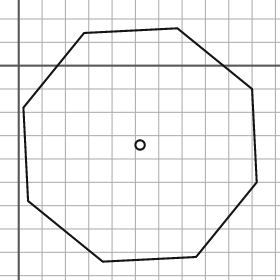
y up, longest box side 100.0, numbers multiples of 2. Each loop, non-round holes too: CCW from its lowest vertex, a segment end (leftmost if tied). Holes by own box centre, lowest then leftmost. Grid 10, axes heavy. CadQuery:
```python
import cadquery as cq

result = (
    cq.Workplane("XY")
    .moveTo(36.0, -84.0)
    .lineTo(76.0, -82.0)
    .lineTo(102.0, -50.0)
    .lineTo(100.0, -10.0)
    .lineTo(68.0, 16.0)
    .lineTo(28.0, 14.0)
    .lineTo(2.0, -18.0)
    .lineTo(4.0, -58.0)
    .close()
    .moveTo(52.0, -34.0)
    .circle(2.0)
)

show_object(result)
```